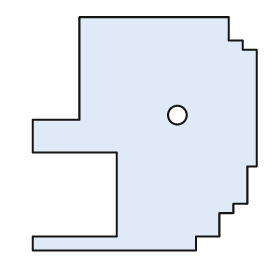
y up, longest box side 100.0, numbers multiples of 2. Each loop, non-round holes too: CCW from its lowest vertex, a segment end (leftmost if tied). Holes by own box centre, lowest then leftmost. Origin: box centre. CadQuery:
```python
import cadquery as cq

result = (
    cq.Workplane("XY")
    .moveTo(-48.0, -50.0)
    .lineTo(22.0, -50.0)
    .lineTo(22.0, -44.0)
    .lineTo(32.0, -44.0)
    .lineTo(32.0, -34.0)
    .lineTo(38.0, -34.0)
    .lineTo(38.0, -30.0)
    .lineTo(44.0, -30.0)
    .lineTo(44.0, -14.0)
    .lineTo(48.0, -14.0)
    .lineTo(48.0, 36.0)
    .lineTo(42.0, 36.0)
    .lineTo(42.0, 40.0)
    .lineTo(36.0, 40.0)
    .lineTo(36.0, 50.0)
    .lineTo(-28.0, 50.0)
    .lineTo(-28.0, 6.0)
    .lineTo(-48.0, 6.0)
    .lineTo(-48.0, -8.0)
    .lineTo(-12.0, -8.0)
    .lineTo(-12.0, -44.0)
    .lineTo(-48.0, -44.0)
    .close()
    .moveTo(14.0, 8.0)
    .circle(4.0)
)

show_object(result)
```